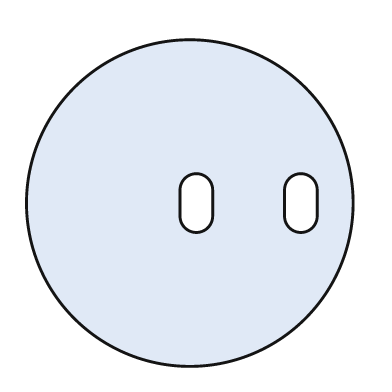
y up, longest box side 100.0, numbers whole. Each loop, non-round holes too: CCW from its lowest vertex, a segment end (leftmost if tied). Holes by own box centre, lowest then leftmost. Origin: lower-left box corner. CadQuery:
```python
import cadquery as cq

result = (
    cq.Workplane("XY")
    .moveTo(50.0, 50.0)
    .circle(50.0)
    .moveTo(47.0, 46.0)
    .threePointArc((52.0, 41.0), (57.0, 46.0))
    .lineTo(57.0, 54.0)
    .threePointArc((52.0, 59.0), (47.0, 54.0))
    .close()
    .moveTo(79.0, 46.0)
    .threePointArc((84.0, 41.0), (89.0, 46.0))
    .lineTo(89.0, 54.0)
    .threePointArc((84.0, 59.0), (79.0, 54.0))
    .close()
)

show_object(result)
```